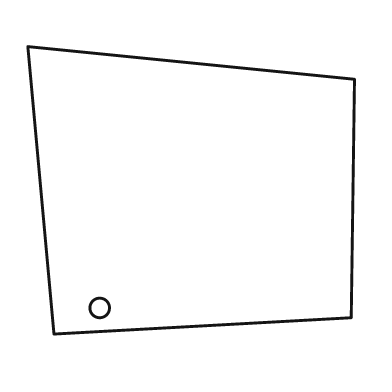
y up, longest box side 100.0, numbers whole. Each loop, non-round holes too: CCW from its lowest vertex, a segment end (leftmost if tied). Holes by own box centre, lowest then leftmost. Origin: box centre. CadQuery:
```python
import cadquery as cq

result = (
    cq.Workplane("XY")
    .moveTo(-42.0, -44.0)
    .lineTo(49.0, -39.0)
    .lineTo(50.0, 34.0)
    .lineTo(-50.0, 44.0)
    .close()
    .moveTo(-28.0, -36.0)
    .circle(3.0)
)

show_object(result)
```